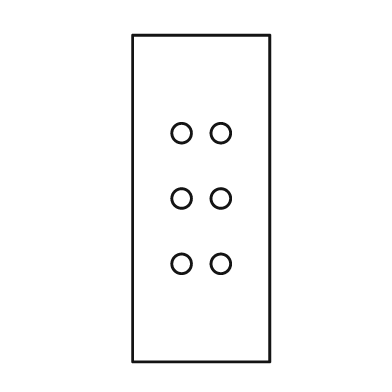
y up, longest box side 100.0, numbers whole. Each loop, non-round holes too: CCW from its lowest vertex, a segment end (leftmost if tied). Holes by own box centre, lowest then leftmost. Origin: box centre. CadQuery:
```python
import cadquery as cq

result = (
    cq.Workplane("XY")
    .moveTo(-21.0, -50.0)
    .lineTo(21.0, -50.0)
    .lineTo(21.0, 50.0)
    .lineTo(-21.0, 50.0)
    .close()
    .moveTo(-6.0, -20.0)
    .circle(3.0)
    .moveTo(6.0, -20.0)
    .circle(3.0)
    .moveTo(-6.0, 0.0)
    .circle(3.0)
    .moveTo(6.0, 0.0)
    .circle(3.0)
    .moveTo(-6.0, 20.0)
    .circle(3.0)
    .moveTo(6.0, 20.0)
    .circle(3.0)
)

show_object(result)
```